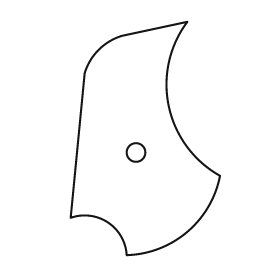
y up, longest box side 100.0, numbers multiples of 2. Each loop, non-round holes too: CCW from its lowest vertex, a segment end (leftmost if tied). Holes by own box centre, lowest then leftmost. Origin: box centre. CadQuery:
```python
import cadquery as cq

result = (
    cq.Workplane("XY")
    .moveTo(-8.0, -50.0)
    .threePointArc((18.0, -40.0), (32.0, -16.0))
    .threePointArc((10.0, 14.0), (18.0, 50.0))
    .lineTo(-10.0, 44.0)
    .threePointArc((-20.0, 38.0), (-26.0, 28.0))
    .lineTo(-32.0, -34.0)
    .threePointArc((-16.0, -36.0), (-8.0, -50.0))
    .close()
    .moveTo(-4.0, -6.0)
    .circle(4.0)
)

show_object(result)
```